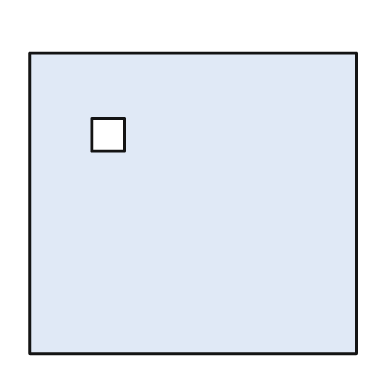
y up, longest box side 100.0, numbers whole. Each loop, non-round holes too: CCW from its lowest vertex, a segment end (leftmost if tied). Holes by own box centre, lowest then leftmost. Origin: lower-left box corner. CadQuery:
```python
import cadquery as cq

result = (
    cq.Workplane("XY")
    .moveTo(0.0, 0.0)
    .lineTo(100.0, 0.0)
    .lineTo(100.0, 92.0)
    .lineTo(0.0, 92.0)
    .close()
    .moveTo(19.0, 62.0)
    .lineTo(29.0, 62.0)
    .lineTo(29.0, 72.0)
    .lineTo(19.0, 72.0)
    .close()
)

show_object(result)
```